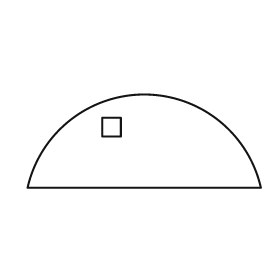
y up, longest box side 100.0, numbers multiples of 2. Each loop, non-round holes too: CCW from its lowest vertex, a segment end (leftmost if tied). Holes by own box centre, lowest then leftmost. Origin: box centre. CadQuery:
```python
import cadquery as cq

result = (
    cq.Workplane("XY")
    .moveTo(-50.0, -20.0)
    .lineTo(50.0, -20.0)
    .threePointArc((0.0, 20.0), (-50.0, -20.0))
    .close()
    .moveTo(-18.0, 2.0)
    .lineTo(-10.0, 2.0)
    .lineTo(-10.0, 10.0)
    .lineTo(-18.0, 10.0)
    .close()
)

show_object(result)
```